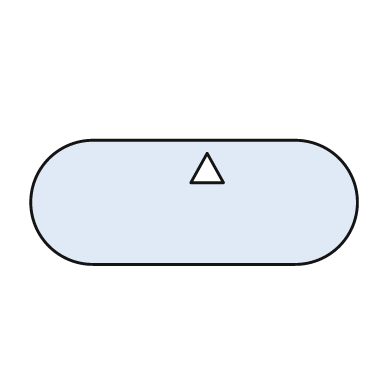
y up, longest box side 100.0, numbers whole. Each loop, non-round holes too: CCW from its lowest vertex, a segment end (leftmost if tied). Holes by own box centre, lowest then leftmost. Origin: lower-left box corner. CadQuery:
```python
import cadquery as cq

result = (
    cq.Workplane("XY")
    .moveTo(19.0, 0.0)
    .lineTo(81.0, 0.0)
    .threePointArc((100.0, 19.0), (81.0, 38.0))
    .lineTo(19.0, 38.0)
    .threePointArc((0.0, 19.0), (19.0, 0.0))
    .close()
    .moveTo(49.0, 25.0)
    .lineTo(59.0, 25.0)
    .lineTo(54.0, 34.0)
    .close()
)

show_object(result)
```